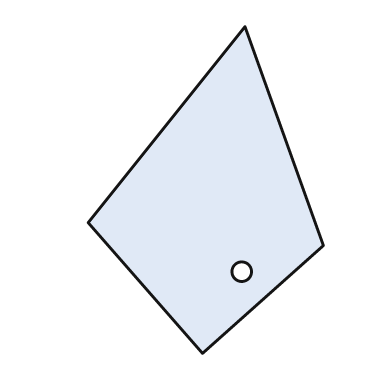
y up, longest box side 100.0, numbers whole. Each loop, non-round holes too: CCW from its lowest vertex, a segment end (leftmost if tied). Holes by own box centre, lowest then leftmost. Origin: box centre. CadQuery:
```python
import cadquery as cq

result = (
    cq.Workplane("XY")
    .moveTo(-1.0, -50.0)
    .lineTo(36.0, -17.0)
    .lineTo(12.0, 50.0)
    .lineTo(-36.0, -10.0)
    .close()
    .moveTo(11.0, -25.0)
    .circle(3.0)
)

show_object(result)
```